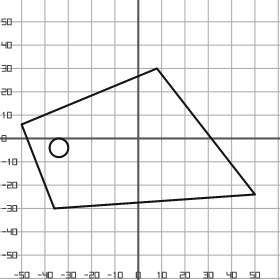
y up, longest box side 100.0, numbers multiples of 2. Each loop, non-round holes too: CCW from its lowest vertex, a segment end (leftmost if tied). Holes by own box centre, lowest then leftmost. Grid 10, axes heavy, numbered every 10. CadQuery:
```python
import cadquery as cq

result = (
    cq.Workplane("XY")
    .moveTo(-36.0, -30.0)
    .lineTo(50.0, -24.0)
    .lineTo(8.0, 30.0)
    .lineTo(-50.0, 6.0)
    .close()
    .moveTo(-34.0, -4.0)
    .circle(4.0)
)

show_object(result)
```